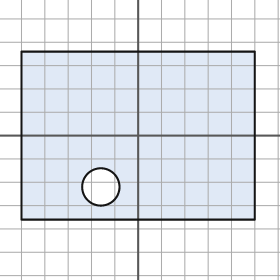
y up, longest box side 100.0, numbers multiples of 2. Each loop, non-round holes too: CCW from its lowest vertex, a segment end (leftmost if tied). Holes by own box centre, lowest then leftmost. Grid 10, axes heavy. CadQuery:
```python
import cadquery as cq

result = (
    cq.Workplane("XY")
    .moveTo(-50.0, -36.0)
    .lineTo(50.0, -36.0)
    .lineTo(50.0, 36.0)
    .lineTo(-50.0, 36.0)
    .close()
    .moveTo(-16.0, -22.0)
    .circle(8.0)
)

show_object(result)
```